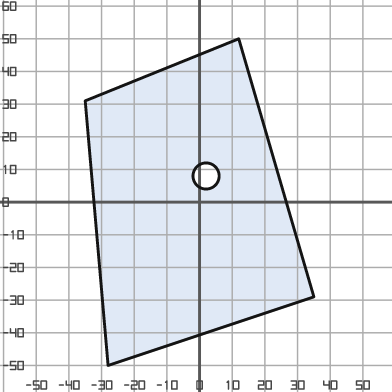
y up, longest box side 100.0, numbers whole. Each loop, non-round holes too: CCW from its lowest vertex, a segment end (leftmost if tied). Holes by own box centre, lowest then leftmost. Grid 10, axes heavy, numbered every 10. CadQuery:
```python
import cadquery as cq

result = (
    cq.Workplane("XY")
    .moveTo(-28.0, -50.0)
    .lineTo(35.0, -29.0)
    .lineTo(12.0, 50.0)
    .lineTo(-35.0, 31.0)
    .close()
    .moveTo(2.0, 8.0)
    .circle(4.0)
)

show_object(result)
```